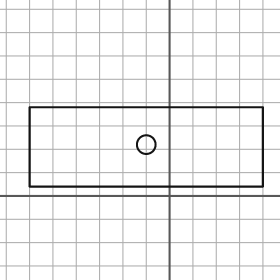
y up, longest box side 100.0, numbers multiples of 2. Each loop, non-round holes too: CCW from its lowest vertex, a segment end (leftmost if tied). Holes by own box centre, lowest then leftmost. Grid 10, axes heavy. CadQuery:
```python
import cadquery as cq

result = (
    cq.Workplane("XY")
    .moveTo(-60.0, 4.0)
    .lineTo(40.0, 4.0)
    .lineTo(40.0, 38.0)
    .lineTo(-60.0, 38.0)
    .close()
    .moveTo(-10.0, 22.0)
    .circle(4.0)
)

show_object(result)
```